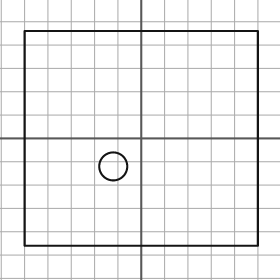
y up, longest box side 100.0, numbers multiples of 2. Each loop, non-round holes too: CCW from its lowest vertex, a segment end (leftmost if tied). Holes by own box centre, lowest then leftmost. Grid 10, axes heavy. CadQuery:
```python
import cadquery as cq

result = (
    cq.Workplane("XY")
    .moveTo(-50.0, -46.0)
    .lineTo(50.0, -46.0)
    .lineTo(50.0, 46.0)
    .lineTo(-50.0, 46.0)
    .close()
    .moveTo(-12.0, -12.0)
    .circle(6.0)
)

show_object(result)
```